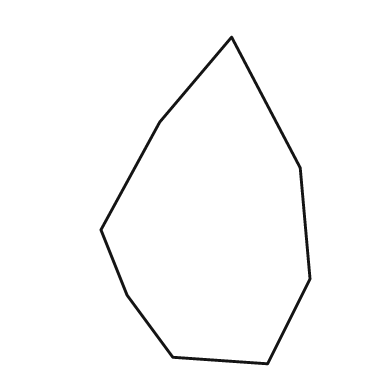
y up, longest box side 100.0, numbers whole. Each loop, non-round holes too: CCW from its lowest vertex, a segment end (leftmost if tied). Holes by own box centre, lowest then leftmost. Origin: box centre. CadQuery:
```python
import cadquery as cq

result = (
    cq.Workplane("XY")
    .moveTo(19.0, -50.0)
    .lineTo(32.0, -24.0)
    .lineTo(29.0, 10.0)
    .lineTo(8.0, 50.0)
    .lineTo(-14.0, 24.0)
    .lineTo(-32.0, -9.0)
    .lineTo(-24.0, -29.0)
    .lineTo(-10.0, -48.0)
    .close()
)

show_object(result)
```